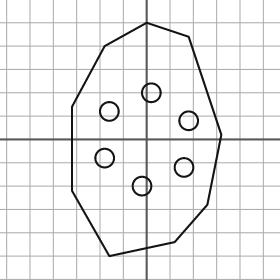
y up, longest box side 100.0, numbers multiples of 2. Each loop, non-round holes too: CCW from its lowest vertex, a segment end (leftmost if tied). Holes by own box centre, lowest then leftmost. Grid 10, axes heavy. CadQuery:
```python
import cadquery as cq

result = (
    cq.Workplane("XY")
    .moveTo(-16.0, -50.0)
    .lineTo(12.0, -44.0)
    .lineTo(26.0, -28.0)
    .lineTo(32.0, 2.0)
    .lineTo(18.0, 44.0)
    .lineTo(0.0, 50.0)
    .lineTo(-18.0, 40.0)
    .lineTo(-32.0, 14.0)
    .lineTo(-32.0, -22.0)
    .close()
    .moveTo(-2.0, -20.0)
    .circle(4.0)
    .moveTo(16.0, -12.0)
    .circle(4.0)
    .moveTo(-18.0, -8.0)
    .circle(4.0)
    .moveTo(18.0, 8.0)
    .circle(4.0)
    .moveTo(-16.0, 12.0)
    .circle(4.0)
    .moveTo(2.0, 20.0)
    .circle(4.0)
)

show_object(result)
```